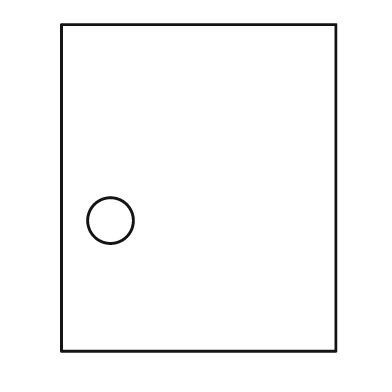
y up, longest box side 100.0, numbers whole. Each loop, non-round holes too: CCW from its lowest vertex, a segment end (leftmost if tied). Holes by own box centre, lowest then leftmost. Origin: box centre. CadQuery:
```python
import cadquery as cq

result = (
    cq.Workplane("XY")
    .moveTo(-42.0, -50.0)
    .lineTo(42.0, -50.0)
    .lineTo(42.0, 50.0)
    .lineTo(-42.0, 50.0)
    .close()
    .moveTo(-27.0, -10.0)
    .circle(7.0)
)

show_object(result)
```